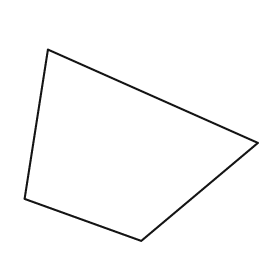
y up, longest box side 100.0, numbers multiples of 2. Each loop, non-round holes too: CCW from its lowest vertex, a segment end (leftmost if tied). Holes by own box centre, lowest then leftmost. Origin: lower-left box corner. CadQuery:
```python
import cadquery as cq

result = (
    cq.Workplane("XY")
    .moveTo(50.0, 0.0)
    .lineTo(100.0, 42.0)
    .lineTo(10.0, 82.0)
    .lineTo(0.0, 18.0)
    .close()
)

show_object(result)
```